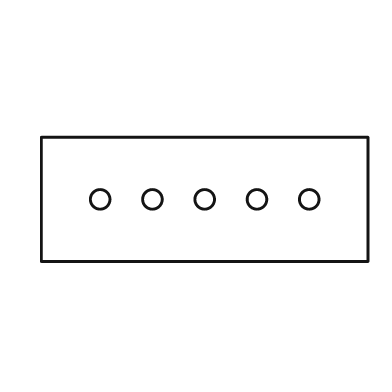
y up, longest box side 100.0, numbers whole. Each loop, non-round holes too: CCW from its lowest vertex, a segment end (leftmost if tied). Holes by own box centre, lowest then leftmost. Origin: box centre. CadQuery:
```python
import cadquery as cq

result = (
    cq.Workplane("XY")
    .moveTo(-50.0, -19.0)
    .lineTo(50.0, -19.0)
    .lineTo(50.0, 19.0)
    .lineTo(-50.0, 19.0)
    .close()
    .moveTo(-32.0, 0.0)
    .circle(3.0)
    .moveTo(-16.0, 0.0)
    .circle(3.0)
    .moveTo(0.0, 0.0)
    .circle(3.0)
    .moveTo(16.0, 0.0)
    .circle(3.0)
    .moveTo(32.0, 0.0)
    .circle(3.0)
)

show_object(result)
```